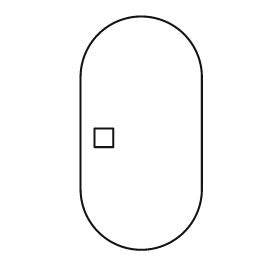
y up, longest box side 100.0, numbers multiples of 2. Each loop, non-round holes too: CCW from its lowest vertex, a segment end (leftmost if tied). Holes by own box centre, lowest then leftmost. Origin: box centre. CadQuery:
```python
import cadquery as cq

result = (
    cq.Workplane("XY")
    .moveTo(-26.0, -24.0)
    .threePointArc((0.0, -50.0), (26.0, -24.0))
    .lineTo(26.0, 24.0)
    .threePointArc((0.0, 50.0), (-26.0, 24.0))
    .close()
    .moveTo(-20.0, -6.0)
    .lineTo(-12.0, -6.0)
    .lineTo(-12.0, 2.0)
    .lineTo(-20.0, 2.0)
    .close()
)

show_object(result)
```